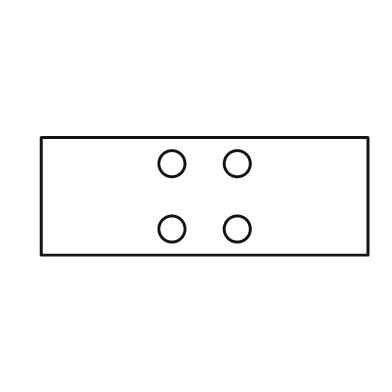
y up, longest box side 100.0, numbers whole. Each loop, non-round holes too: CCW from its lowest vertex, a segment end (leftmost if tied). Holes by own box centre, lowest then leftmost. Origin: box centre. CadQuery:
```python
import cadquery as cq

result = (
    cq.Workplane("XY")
    .moveTo(-50.0, -18.0)
    .lineTo(50.0, -18.0)
    .lineTo(50.0, 18.0)
    .lineTo(-50.0, 18.0)
    .close()
    .moveTo(-10.0, -10.0)
    .circle(4.0)
    .moveTo(10.0, -10.0)
    .circle(4.0)
    .moveTo(-10.0, 10.0)
    .circle(4.0)
    .moveTo(10.0, 10.0)
    .circle(4.0)
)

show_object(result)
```